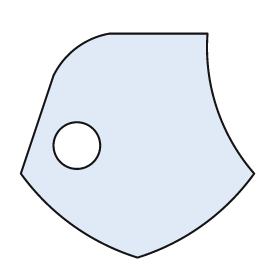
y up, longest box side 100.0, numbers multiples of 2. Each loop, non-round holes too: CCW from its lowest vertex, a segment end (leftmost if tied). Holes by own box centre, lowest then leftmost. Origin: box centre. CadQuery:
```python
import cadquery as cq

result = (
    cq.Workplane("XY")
    .moveTo(0.0, -48.0)
    .threePointArc((28.0, -34.0), (50.0, -12.0))
    .threePointArc((34.0, 16.0), (30.0, 48.0))
    .lineTo(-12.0, 48.0)
    .threePointArc((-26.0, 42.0), (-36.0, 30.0))
    .lineTo(-50.0, -12.0)
    .threePointArc((-28.0, -34.0), (0.0, -48.0))
    .close()
    .moveTo(-26.0, 0.0)
    .circle(10.0)
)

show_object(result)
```